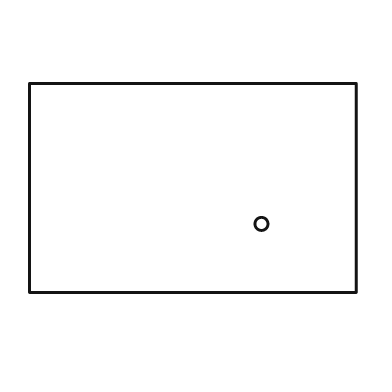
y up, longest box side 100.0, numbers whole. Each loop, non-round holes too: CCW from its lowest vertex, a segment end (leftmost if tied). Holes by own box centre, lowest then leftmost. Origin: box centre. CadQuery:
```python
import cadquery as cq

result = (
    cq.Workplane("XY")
    .moveTo(-50.0, -32.0)
    .lineTo(50.0, -32.0)
    .lineTo(50.0, 32.0)
    .lineTo(-50.0, 32.0)
    .close()
    .moveTo(21.0, -11.0)
    .circle(2.0)
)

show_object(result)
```